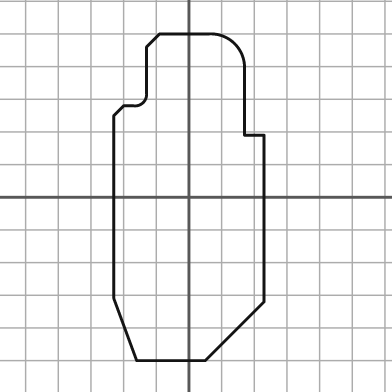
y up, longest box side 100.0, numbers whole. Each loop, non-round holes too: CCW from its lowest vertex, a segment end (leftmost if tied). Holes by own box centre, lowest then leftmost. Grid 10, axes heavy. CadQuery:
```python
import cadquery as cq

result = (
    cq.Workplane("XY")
    .moveTo(-16.0, -50.0)
    .lineTo(5.0, -50.0)
    .lineTo(23.0, -32.0)
    .lineTo(23.0, 19.0)
    .lineTo(17.0, 19.0)
    .lineTo(17.0, 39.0)
    .threePointArc((14.0, 47.0), (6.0, 50.0))
    .lineTo(-9.0, 50.0)
    .lineTo(-13.0, 46.0)
    .lineTo(-13.0, 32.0)
    .threePointArc((-14.0, 29.0), (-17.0, 28.0))
    .lineTo(-20.0, 28.0)
    .lineTo(-23.0, 25.0)
    .lineTo(-23.0, -31.0)
    .close()
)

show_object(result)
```